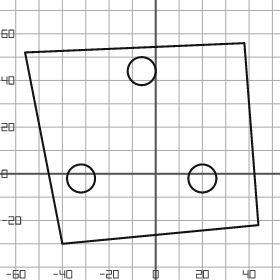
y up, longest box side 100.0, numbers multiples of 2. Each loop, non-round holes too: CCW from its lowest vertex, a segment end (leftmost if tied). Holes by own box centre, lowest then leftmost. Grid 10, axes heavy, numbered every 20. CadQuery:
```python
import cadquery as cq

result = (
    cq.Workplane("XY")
    .moveTo(-40.0, -30.0)
    .lineTo(44.0, -22.0)
    .lineTo(38.0, 56.0)
    .lineTo(-56.0, 52.0)
    .close()
    .moveTo(-32.0, -2.0)
    .circle(6.0)
    .moveTo(20.0, -2.0)
    .circle(6.0)
    .moveTo(-6.0, 44.0)
    .circle(6.0)
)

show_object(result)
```